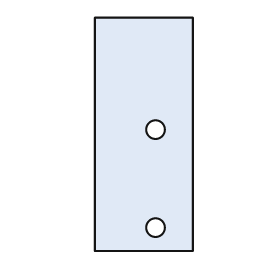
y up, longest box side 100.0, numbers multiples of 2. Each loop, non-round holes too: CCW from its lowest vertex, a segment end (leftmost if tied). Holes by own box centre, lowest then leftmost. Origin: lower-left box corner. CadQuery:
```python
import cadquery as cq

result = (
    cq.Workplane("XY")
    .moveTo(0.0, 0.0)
    .lineTo(42.0, 0.0)
    .lineTo(42.0, 100.0)
    .lineTo(0.0, 100.0)
    .close()
    .moveTo(26.0, 10.0)
    .circle(4.0)
    .moveTo(26.0, 52.0)
    .circle(4.0)
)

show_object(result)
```